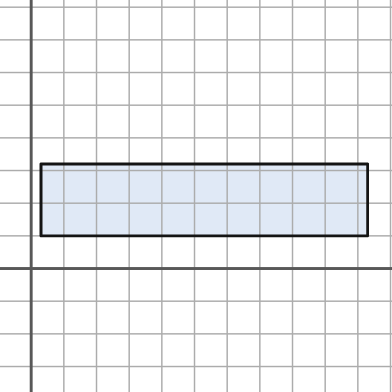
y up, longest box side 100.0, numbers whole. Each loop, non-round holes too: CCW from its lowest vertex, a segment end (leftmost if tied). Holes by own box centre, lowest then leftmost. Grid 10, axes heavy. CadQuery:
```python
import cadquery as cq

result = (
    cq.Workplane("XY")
    .moveTo(3.0, 10.0)
    .lineTo(103.0, 10.0)
    .lineTo(103.0, 32.0)
    .lineTo(3.0, 32.0)
    .close()
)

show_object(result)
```